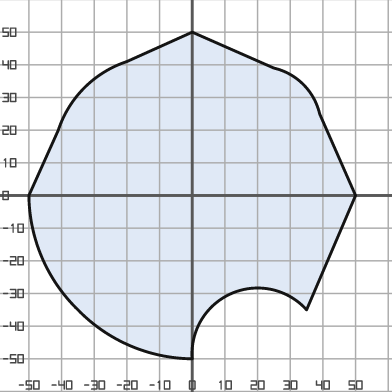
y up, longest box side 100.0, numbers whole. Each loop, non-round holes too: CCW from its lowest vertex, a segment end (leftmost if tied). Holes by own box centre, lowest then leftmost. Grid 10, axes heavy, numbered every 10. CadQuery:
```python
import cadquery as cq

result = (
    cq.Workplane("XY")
    .moveTo(0.0, -50.0)
    .threePointArc((12.0, -30.0), (35.0, -35.0))
    .lineTo(50.0, 0.0)
    .lineTo(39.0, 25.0)
    .threePointArc((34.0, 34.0), (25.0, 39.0))
    .lineTo(0.0, 50.0)
    .lineTo(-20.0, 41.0)
    .threePointArc((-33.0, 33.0), (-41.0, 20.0))
    .lineTo(-50.0, 0.0)
    .threePointArc((-46.0, -19.0), (-35.0, -35.0))
    .threePointArc((-19.0, -46.0), (0.0, -50.0))
    .close()
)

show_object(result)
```